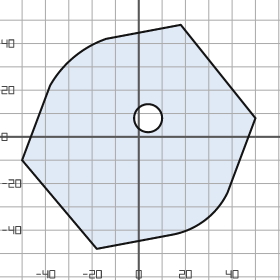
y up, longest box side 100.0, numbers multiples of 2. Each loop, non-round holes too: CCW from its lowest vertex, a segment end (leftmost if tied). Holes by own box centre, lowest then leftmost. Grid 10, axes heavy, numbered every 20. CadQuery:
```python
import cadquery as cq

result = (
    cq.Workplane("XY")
    .moveTo(-18.0, -48.0)
    .lineTo(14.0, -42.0)
    .threePointArc((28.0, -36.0), (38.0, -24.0))
    .lineTo(50.0, 8.0)
    .lineTo(18.0, 48.0)
    .lineTo(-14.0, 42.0)
    .threePointArc((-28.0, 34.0), (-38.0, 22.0))
    .lineTo(-50.0, -10.0)
    .close()
    .moveTo(4.0, 8.0)
    .circle(6.0)
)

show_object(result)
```